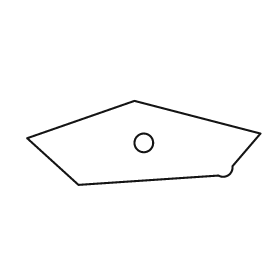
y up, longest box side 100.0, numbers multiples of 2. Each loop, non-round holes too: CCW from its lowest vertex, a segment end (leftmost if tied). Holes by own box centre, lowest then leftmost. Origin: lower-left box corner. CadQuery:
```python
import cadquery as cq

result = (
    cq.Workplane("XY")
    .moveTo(22.0, 0.0)
    .lineTo(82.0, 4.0)
    .threePointArc((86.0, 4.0), (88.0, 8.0))
    .lineTo(100.0, 22.0)
    .lineTo(46.0, 36.0)
    .lineTo(0.0, 20.0)
    .close()
    .moveTo(50.0, 18.0)
    .circle(4.0)
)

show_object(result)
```